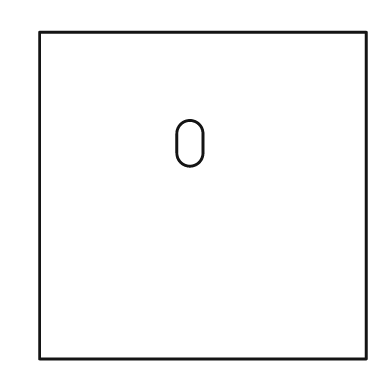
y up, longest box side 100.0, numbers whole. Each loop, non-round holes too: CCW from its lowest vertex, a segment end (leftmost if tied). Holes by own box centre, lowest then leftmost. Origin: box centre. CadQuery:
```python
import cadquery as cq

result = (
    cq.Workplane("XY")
    .moveTo(-50.0, -50.0)
    .lineTo(50.0, -50.0)
    .lineTo(50.0, 50.0)
    .lineTo(-50.0, 50.0)
    .close()
    .moveTo(-8.0, 13.0)
    .threePointArc((-4.0, 9.0), (0.0, 13.0))
    .lineTo(0.0, 19.0)
    .threePointArc((-4.0, 23.0), (-8.0, 19.0))
    .close()
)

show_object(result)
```